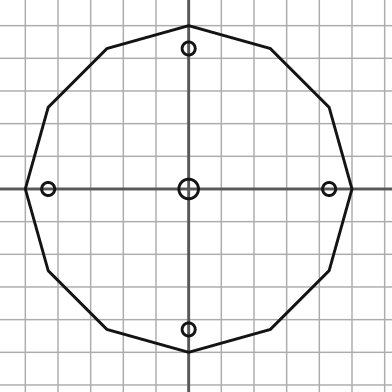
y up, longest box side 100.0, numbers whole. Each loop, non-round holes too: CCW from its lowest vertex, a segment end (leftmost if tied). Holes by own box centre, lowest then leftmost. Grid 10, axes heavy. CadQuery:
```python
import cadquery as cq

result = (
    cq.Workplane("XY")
    .moveTo(0.0, -50.0)
    .lineTo(25.0, -43.0)
    .lineTo(43.0, -25.0)
    .lineTo(50.0, 0.0)
    .lineTo(43.0, 25.0)
    .lineTo(25.0, 43.0)
    .lineTo(0.0, 50.0)
    .lineTo(-25.0, 43.0)
    .lineTo(-43.0, 25.0)
    .lineTo(-50.0, 0.0)
    .lineTo(-43.0, -25.0)
    .lineTo(-25.0, -43.0)
    .close()
    .moveTo(0.0, -43.0)
    .circle(2.0)
    .moveTo(-43.0, 0.0)
    .circle(2.0)
    .moveTo(0.0, 0.0)
    .circle(3.0)
    .moveTo(43.0, 0.0)
    .circle(2.0)
    .moveTo(0.0, 43.0)
    .circle(2.0)
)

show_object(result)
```